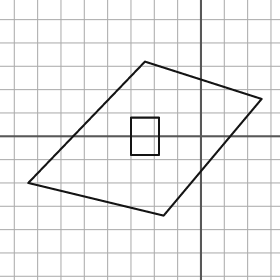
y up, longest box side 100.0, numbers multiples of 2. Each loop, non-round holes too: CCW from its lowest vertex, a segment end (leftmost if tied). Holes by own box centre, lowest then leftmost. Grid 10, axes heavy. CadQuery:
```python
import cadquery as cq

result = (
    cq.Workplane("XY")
    .moveTo(-16.0, -34.0)
    .lineTo(26.0, 16.0)
    .lineTo(-24.0, 32.0)
    .lineTo(-74.0, -20.0)
    .close()
    .moveTo(-30.0, -8.0)
    .lineTo(-18.0, -8.0)
    .lineTo(-18.0, 8.0)
    .lineTo(-30.0, 8.0)
    .close()
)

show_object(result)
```